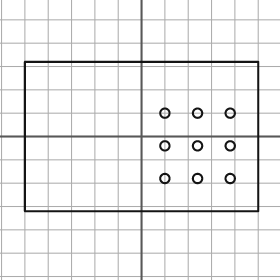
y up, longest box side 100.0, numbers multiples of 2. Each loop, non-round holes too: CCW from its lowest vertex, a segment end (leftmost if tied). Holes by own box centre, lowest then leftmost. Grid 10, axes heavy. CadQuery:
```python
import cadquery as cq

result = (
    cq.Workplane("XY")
    .moveTo(-50.0, -32.0)
    .lineTo(50.0, -32.0)
    .lineTo(50.0, 32.0)
    .lineTo(-50.0, 32.0)
    .close()
    .moveTo(10.0, -18.0)
    .circle(2.0)
    .moveTo(24.0, -18.0)
    .circle(2.0)
    .moveTo(38.0, -18.0)
    .circle(2.0)
    .moveTo(10.0, -4.0)
    .circle(2.0)
    .moveTo(24.0, -4.0)
    .circle(2.0)
    .moveTo(38.0, -4.0)
    .circle(2.0)
    .moveTo(10.0, 10.0)
    .circle(2.0)
    .moveTo(24.0, 10.0)
    .circle(2.0)
    .moveTo(38.0, 10.0)
    .circle(2.0)
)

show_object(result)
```